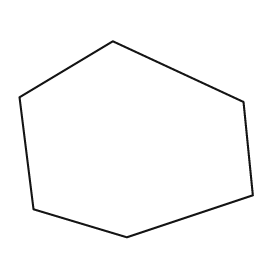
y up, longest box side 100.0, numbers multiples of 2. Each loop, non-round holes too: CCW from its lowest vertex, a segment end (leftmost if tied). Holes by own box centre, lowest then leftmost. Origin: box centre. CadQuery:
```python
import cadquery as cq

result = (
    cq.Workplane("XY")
    .moveTo(-4.0, -42.0)
    .lineTo(50.0, -24.0)
    .lineTo(46.0, 16.0)
    .lineTo(-10.0, 42.0)
    .lineTo(-50.0, 18.0)
    .lineTo(-44.0, -30.0)
    .close()
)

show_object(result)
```